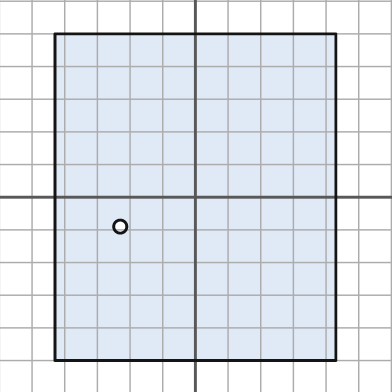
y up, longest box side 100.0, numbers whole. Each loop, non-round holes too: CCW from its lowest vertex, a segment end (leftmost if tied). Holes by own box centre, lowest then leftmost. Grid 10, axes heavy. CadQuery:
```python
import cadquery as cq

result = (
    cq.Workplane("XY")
    .moveTo(-43.0, -50.0)
    .lineTo(43.0, -50.0)
    .lineTo(43.0, 50.0)
    .lineTo(-43.0, 50.0)
    .close()
    .moveTo(-23.0, -9.0)
    .circle(2.0)
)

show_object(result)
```